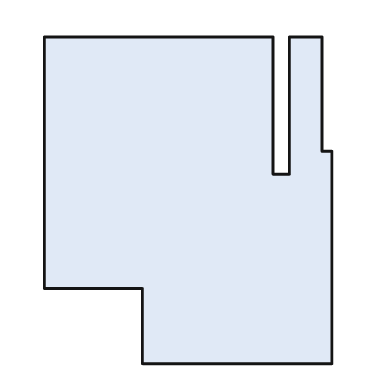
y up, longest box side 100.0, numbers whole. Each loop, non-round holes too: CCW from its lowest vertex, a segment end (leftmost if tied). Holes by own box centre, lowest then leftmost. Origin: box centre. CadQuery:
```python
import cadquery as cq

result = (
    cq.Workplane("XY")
    .moveTo(-14.0, -50.0)
    .lineTo(44.0, -50.0)
    .lineTo(44.0, 15.0)
    .lineTo(41.0, 15.0)
    .lineTo(41.0, 50.0)
    .lineTo(31.0, 50.0)
    .lineTo(31.0, 8.0)
    .lineTo(26.0, 8.0)
    .lineTo(26.0, 50.0)
    .lineTo(-44.0, 50.0)
    .lineTo(-44.0, -27.0)
    .lineTo(-14.0, -27.0)
    .close()
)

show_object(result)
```